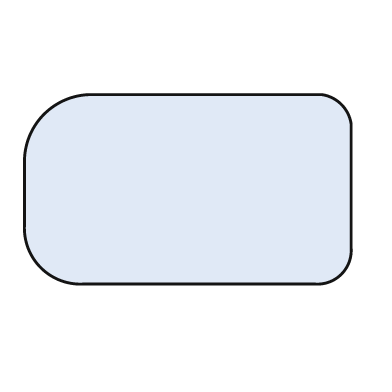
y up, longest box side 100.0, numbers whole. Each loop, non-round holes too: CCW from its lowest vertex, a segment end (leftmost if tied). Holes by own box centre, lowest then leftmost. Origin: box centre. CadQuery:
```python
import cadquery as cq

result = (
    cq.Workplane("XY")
    .moveTo(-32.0, -29.0)
    .lineTo(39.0, -29.0)
    .threePointArc((47.0, -26.0), (50.0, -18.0))
    .lineTo(50.0, 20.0)
    .threePointArc((47.0, 26.0), (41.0, 29.0))
    .lineTo(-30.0, 29.0)
    .threePointArc((-44.0, 23.0), (-50.0, 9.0))
    .lineTo(-50.0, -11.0)
    .threePointArc((-45.0, -24.0), (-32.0, -29.0))
    .close()
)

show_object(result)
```